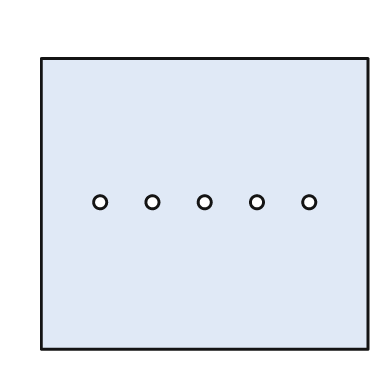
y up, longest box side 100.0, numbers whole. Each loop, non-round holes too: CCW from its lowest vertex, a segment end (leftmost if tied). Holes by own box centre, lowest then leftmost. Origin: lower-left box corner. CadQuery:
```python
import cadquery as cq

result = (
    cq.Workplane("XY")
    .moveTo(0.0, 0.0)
    .lineTo(100.0, 0.0)
    .lineTo(100.0, 89.0)
    .lineTo(0.0, 89.0)
    .close()
    .moveTo(18.0, 45.0)
    .circle(2.0)
    .moveTo(34.0, 45.0)
    .circle(2.0)
    .moveTo(50.0, 45.0)
    .circle(2.0)
    .moveTo(66.0, 45.0)
    .circle(2.0)
    .moveTo(82.0, 45.0)
    .circle(2.0)
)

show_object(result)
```